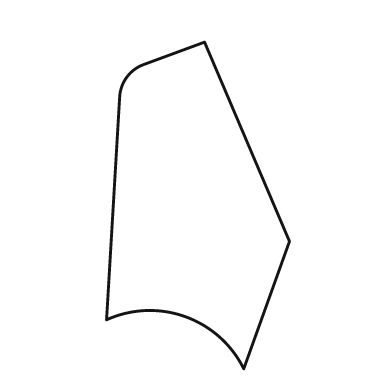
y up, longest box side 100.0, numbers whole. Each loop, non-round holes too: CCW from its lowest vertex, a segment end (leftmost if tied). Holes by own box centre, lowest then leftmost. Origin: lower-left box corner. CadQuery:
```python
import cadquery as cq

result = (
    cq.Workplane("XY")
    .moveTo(42.0, 0.0)
    .lineTo(56.0, 39.0)
    .lineTo(30.0, 100.0)
    .lineTo(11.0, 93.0)
    .threePointArc((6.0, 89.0), (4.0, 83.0))
    .lineTo(0.0, 15.0)
    .threePointArc((24.0, 16.0), (42.0, 0.0))
    .close()
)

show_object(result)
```